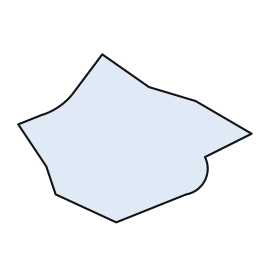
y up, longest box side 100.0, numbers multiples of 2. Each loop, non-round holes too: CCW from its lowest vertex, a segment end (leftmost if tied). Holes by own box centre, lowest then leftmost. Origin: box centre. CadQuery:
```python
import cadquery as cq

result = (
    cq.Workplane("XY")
    .moveTo(-8.0, -36.0)
    .lineTo(22.0, -24.0)
    .threePointArc((30.0, -18.0), (30.0, -8.0))
    .lineTo(50.0, 2.0)
    .lineTo(26.0, 16.0)
    .lineTo(6.0, 22.0)
    .lineTo(-14.0, 36.0)
    .lineTo(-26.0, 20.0)
    .threePointArc((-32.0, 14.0), (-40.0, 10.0))
    .lineTo(-50.0, 6.0)
    .lineTo(-38.0, -12.0)
    .lineTo(-34.0, -24.0)
    .close()
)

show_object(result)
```